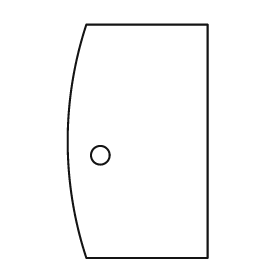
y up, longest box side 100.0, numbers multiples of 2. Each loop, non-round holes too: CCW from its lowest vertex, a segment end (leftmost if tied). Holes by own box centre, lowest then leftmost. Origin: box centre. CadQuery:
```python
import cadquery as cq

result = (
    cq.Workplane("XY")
    .moveTo(-22.0, -50.0)
    .lineTo(30.0, -50.0)
    .lineTo(30.0, 50.0)
    .lineTo(-22.0, 50.0)
    .threePointArc((-30.0, 0.0), (-22.0, -50.0))
    .close()
    .moveTo(-16.0, -6.0)
    .circle(4.0)
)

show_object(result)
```